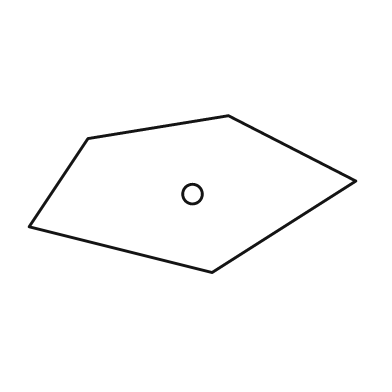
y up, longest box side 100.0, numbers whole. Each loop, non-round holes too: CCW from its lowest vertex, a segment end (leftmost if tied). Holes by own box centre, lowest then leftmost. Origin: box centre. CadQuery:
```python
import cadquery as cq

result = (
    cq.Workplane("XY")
    .moveTo(6.0, -24.0)
    .lineTo(50.0, 4.0)
    .lineTo(11.0, 24.0)
    .lineTo(-32.0, 17.0)
    .lineTo(-50.0, -10.0)
    .close()
    .moveTo(0.0, 0.0)
    .circle(3.0)
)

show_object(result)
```